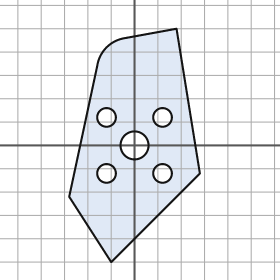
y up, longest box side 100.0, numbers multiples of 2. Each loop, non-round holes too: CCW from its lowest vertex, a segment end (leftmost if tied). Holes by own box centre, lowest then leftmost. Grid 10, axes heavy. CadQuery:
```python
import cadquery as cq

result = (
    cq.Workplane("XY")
    .moveTo(-10.0, -50.0)
    .lineTo(28.0, -12.0)
    .lineTo(18.0, 50.0)
    .lineTo(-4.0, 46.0)
    .threePointArc((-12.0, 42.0), (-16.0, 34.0))
    .lineTo(-28.0, -22.0)
    .close()
    .moveTo(-12.0, -12.0)
    .circle(4.0)
    .moveTo(12.0, -12.0)
    .circle(4.0)
    .moveTo(0.0, 0.0)
    .circle(6.0)
    .moveTo(-12.0, 12.0)
    .circle(4.0)
    .moveTo(12.0, 12.0)
    .circle(4.0)
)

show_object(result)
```